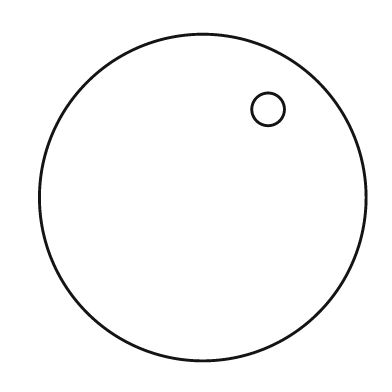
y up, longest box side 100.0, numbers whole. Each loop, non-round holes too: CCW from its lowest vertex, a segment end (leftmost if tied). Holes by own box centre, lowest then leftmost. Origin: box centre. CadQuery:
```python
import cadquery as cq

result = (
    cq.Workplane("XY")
    .moveTo(0.0, 0.0)
    .circle(50.0)
    .moveTo(20.0, 27.0)
    .circle(5.0)
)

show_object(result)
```